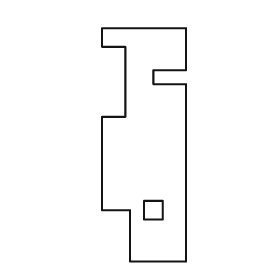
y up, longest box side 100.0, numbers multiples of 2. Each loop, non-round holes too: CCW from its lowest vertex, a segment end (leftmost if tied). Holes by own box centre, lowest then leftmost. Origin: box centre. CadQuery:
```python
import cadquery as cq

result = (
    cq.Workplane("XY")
    .moveTo(-6.0, -50.0)
    .lineTo(18.0, -50.0)
    .lineTo(18.0, 26.0)
    .lineTo(4.0, 26.0)
    .lineTo(4.0, 32.0)
    .lineTo(18.0, 32.0)
    .lineTo(18.0, 50.0)
    .lineTo(-18.0, 50.0)
    .lineTo(-18.0, 42.0)
    .lineTo(-8.0, 42.0)
    .lineTo(-8.0, 12.0)
    .lineTo(-18.0, 12.0)
    .lineTo(-18.0, -28.0)
    .lineTo(-6.0, -28.0)
    .close()
    .moveTo(0.0, -32.0)
    .lineTo(8.0, -32.0)
    .lineTo(8.0, -24.0)
    .lineTo(0.0, -24.0)
    .close()
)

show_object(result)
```